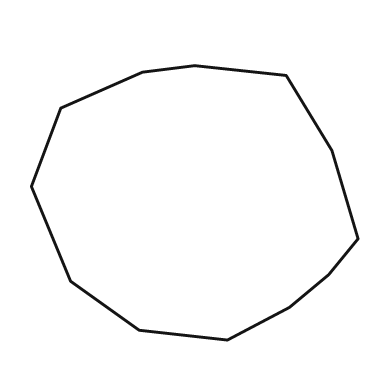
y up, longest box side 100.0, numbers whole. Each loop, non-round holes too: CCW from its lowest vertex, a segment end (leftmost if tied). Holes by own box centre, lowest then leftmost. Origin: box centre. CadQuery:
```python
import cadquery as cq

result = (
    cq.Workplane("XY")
    .moveTo(10.0, -42.0)
    .lineTo(29.0, -32.0)
    .lineTo(41.0, -22.0)
    .lineTo(50.0, -11.0)
    .lineTo(42.0, 16.0)
    .lineTo(28.0, 39.0)
    .lineTo(0.0, 42.0)
    .lineTo(-16.0, 40.0)
    .lineTo(-41.0, 29.0)
    .lineTo(-50.0, 5.0)
    .lineTo(-38.0, -24.0)
    .lineTo(-17.0, -39.0)
    .close()
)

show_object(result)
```